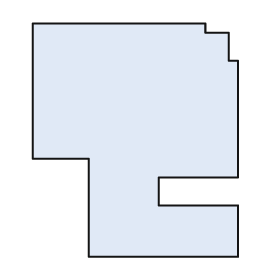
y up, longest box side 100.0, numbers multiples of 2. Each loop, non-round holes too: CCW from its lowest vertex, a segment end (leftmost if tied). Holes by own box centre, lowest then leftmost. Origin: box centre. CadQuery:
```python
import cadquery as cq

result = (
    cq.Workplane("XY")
    .moveTo(-20.0, -50.0)
    .lineTo(44.0, -50.0)
    .lineTo(44.0, -28.0)
    .lineTo(10.0, -28.0)
    .lineTo(10.0, -16.0)
    .lineTo(44.0, -16.0)
    .lineTo(44.0, 34.0)
    .lineTo(40.0, 34.0)
    .lineTo(40.0, 46.0)
    .lineTo(30.0, 46.0)
    .lineTo(30.0, 50.0)
    .lineTo(-44.0, 50.0)
    .lineTo(-44.0, -8.0)
    .lineTo(-20.0, -8.0)
    .close()
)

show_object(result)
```